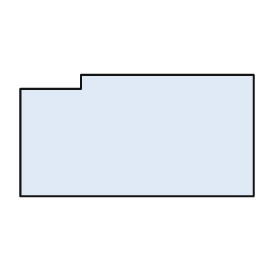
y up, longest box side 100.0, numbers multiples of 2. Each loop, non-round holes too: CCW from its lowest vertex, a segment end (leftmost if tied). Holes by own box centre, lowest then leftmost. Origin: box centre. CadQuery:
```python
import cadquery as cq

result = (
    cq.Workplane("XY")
    .moveTo(-50.0, -26.0)
    .lineTo(50.0, -26.0)
    .lineTo(50.0, 26.0)
    .lineTo(-24.0, 26.0)
    .lineTo(-24.0, 20.0)
    .lineTo(-50.0, 20.0)
    .close()
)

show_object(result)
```